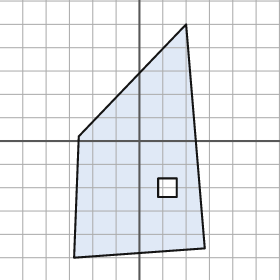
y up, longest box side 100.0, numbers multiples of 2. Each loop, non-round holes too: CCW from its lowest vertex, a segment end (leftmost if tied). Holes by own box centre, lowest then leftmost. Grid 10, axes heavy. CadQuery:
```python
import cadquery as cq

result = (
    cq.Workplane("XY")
    .moveTo(-28.0, -50.0)
    .lineTo(28.0, -46.0)
    .lineTo(20.0, 50.0)
    .lineTo(-26.0, 2.0)
    .close()
    .moveTo(8.0, -24.0)
    .lineTo(16.0, -24.0)
    .lineTo(16.0, -16.0)
    .lineTo(8.0, -16.0)
    .close()
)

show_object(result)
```